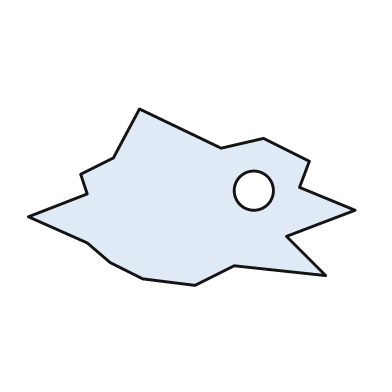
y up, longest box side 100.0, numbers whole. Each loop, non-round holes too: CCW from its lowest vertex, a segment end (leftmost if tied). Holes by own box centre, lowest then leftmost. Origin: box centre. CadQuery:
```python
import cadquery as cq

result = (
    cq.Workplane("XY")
    .moveTo(1.0, -27.0)
    .lineTo(13.0, -21.0)
    .lineTo(41.0, -24.0)
    .lineTo(29.0, -12.0)
    .lineTo(50.0, -4.0)
    .lineTo(33.0, 3.0)
    .lineTo(36.0, 11.0)
    .lineTo(22.0, 18.0)
    .lineTo(9.0, 15.0)
    .lineTo(-16.0, 27.0)
    .lineTo(-24.0, 12.0)
    .lineTo(-34.0, 7.0)
    .lineTo(-32.0, 1.0)
    .lineTo(-50.0, -6.0)
    .lineTo(-32.0, -14.0)
    .lineTo(-25.0, -20.0)
    .lineTo(-15.0, -25.0)
    .close()
    .moveTo(19.0, 2.0)
    .circle(6.0)
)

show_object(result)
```